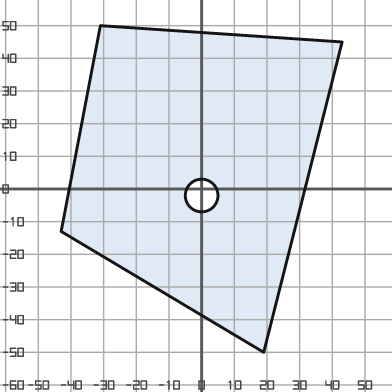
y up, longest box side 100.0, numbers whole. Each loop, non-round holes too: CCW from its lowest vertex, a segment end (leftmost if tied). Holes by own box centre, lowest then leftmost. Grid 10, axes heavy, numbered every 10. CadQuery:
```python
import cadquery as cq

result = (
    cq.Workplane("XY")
    .moveTo(19.0, -50.0)
    .lineTo(43.0, 45.0)
    .lineTo(-31.0, 50.0)
    .lineTo(-43.0, -13.0)
    .close()
    .moveTo(0.0, -2.0)
    .circle(5.0)
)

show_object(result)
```